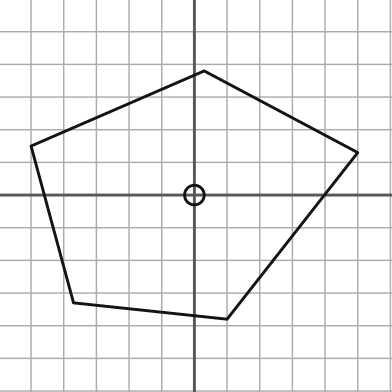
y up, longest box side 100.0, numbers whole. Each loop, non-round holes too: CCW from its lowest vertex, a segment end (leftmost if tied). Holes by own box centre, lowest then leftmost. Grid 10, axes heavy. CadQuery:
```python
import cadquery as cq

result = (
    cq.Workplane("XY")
    .moveTo(10.0, -38.0)
    .lineTo(50.0, 13.0)
    .lineTo(3.0, 38.0)
    .lineTo(-50.0, 15.0)
    .lineTo(-37.0, -33.0)
    .close()
    .moveTo(0.0, 0.0)
    .circle(3.0)
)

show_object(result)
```